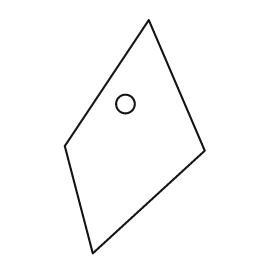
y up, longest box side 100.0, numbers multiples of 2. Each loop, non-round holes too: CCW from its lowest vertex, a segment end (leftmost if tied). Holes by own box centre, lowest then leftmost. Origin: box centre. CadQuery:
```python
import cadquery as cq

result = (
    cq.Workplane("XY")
    .moveTo(-18.0, -50.0)
    .lineTo(30.0, -6.0)
    .lineTo(6.0, 50.0)
    .lineTo(-30.0, -4.0)
    .close()
    .moveTo(-4.0, 14.0)
    .circle(4.0)
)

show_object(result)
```